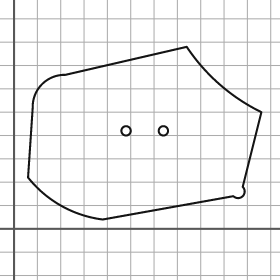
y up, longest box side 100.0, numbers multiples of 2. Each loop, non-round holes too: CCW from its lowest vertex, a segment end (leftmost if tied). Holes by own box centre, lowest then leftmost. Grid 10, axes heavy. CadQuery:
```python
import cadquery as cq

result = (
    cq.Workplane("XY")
    .moveTo(38.0, 4.0)
    .lineTo(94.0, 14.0)
    .threePointArc((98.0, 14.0), (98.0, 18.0))
    .lineTo(106.0, 50.0)
    .threePointArc((88.0, 62.0), (74.0, 78.0))
    .lineTo(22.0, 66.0)
    .threePointArc((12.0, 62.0), (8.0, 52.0))
    .lineTo(6.0, 22.0)
    .threePointArc((20.0, 10.0), (38.0, 4.0))
    .close()
    .moveTo(48.0, 42.0)
    .circle(2.0)
    .moveTo(64.0, 42.0)
    .circle(2.0)
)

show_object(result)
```